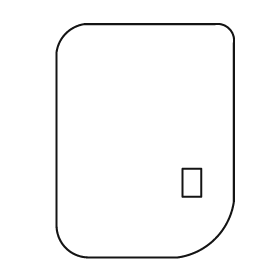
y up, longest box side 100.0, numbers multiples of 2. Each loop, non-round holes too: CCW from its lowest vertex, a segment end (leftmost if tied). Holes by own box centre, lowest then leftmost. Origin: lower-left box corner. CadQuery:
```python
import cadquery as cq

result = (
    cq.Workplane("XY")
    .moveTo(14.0, 0.0)
    .lineTo(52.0, 0.0)
    .threePointArc((68.0, 8.0), (76.0, 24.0))
    .lineTo(76.0, 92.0)
    .threePointArc((74.0, 98.0), (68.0, 100.0))
    .lineTo(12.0, 100.0)
    .threePointArc((4.0, 96.0), (0.0, 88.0))
    .lineTo(0.0, 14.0)
    .threePointArc((4.0, 4.0), (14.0, 0.0))
    .close()
    .moveTo(54.0, 26.0)
    .lineTo(62.0, 26.0)
    .lineTo(62.0, 38.0)
    .lineTo(54.0, 38.0)
    .close()
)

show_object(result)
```